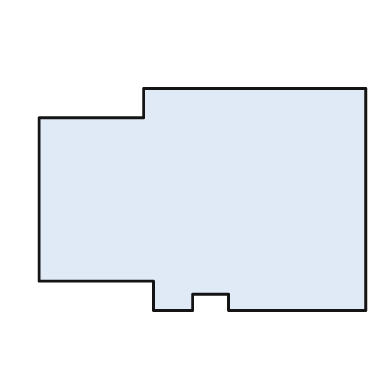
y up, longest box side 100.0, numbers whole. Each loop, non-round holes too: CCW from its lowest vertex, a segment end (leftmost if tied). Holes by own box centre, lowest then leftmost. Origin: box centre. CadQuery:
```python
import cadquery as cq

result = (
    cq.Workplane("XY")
    .moveTo(-15.0, -34.0)
    .lineTo(-3.0, -34.0)
    .lineTo(-3.0, -29.0)
    .lineTo(8.0, -29.0)
    .lineTo(8.0, -34.0)
    .lineTo(50.0, -34.0)
    .lineTo(50.0, 34.0)
    .lineTo(-18.0, 34.0)
    .lineTo(-18.0, 25.0)
    .lineTo(-50.0, 25.0)
    .lineTo(-50.0, -25.0)
    .lineTo(-15.0, -25.0)
    .close()
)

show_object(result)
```